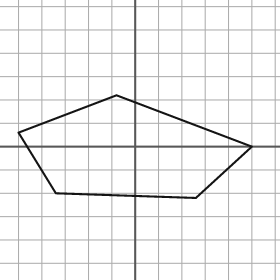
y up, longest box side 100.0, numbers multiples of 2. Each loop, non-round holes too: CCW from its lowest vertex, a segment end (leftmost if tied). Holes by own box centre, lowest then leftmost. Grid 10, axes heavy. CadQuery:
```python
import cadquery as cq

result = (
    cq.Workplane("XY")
    .moveTo(26.0, -22.0)
    .lineTo(50.0, 0.0)
    .lineTo(-8.0, 22.0)
    .lineTo(-50.0, 6.0)
    .lineTo(-34.0, -20.0)
    .close()
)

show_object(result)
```